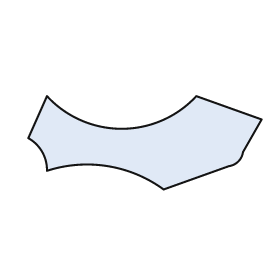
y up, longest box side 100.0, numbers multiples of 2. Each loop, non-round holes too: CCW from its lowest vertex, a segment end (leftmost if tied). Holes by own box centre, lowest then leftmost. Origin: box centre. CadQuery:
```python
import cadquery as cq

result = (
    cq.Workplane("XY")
    .moveTo(8.0, -20.0)
    .lineTo(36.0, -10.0)
    .threePointArc((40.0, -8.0), (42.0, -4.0))
    .lineTo(50.0, 10.0)
    .lineTo(22.0, 20.0)
    .threePointArc((-10.0, 6.0), (-42.0, 20.0))
    .lineTo(-50.0, 2.0)
    .threePointArc((-44.0, -4.0), (-42.0, -12.0))
    .threePointArc((-16.0, -10.0), (8.0, -20.0))
    .close()
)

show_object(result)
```